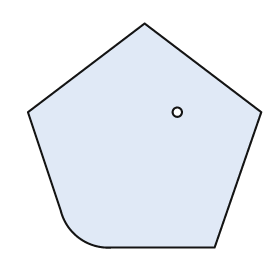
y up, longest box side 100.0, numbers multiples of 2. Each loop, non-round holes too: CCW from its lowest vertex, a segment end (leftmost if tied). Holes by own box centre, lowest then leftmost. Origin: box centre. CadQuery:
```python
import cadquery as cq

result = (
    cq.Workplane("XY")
    .moveTo(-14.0, -48.0)
    .lineTo(30.0, -48.0)
    .lineTo(50.0, 10.0)
    .lineTo(0.0, 48.0)
    .lineTo(-50.0, 10.0)
    .lineTo(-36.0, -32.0)
    .threePointArc((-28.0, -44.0), (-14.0, -48.0))
    .close()
    .moveTo(14.0, 10.0)
    .circle(2.0)
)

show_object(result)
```